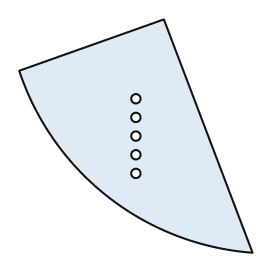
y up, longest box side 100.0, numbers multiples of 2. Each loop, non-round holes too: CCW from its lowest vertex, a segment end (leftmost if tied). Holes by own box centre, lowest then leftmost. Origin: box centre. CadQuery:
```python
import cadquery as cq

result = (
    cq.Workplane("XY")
    .moveTo(50.0, -50.0)
    .lineTo(12.0, 50.0)
    .lineTo(-50.0, 28.0)
    .threePointArc((-12.0, -26.0), (50.0, -50.0))
    .close()
    .moveTo(0.0, -16.0)
    .circle(2.0)
    .moveTo(0.0, -8.0)
    .circle(2.0)
    .moveTo(0.0, 0.0)
    .circle(2.0)
    .moveTo(0.0, 8.0)
    .circle(2.0)
    .moveTo(0.0, 16.0)
    .circle(2.0)
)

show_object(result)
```